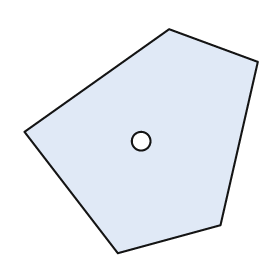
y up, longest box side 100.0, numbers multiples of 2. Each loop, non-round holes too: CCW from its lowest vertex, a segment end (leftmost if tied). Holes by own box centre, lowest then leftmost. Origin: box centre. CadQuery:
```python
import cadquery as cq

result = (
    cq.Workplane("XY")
    .moveTo(-10.0, -48.0)
    .lineTo(34.0, -36.0)
    .lineTo(50.0, 34.0)
    .lineTo(12.0, 48.0)
    .lineTo(-50.0, 4.0)
    .close()
    .moveTo(0.0, 0.0)
    .circle(4.0)
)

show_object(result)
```